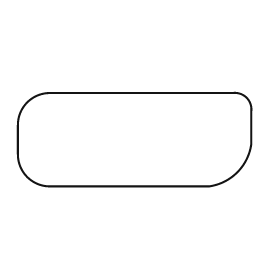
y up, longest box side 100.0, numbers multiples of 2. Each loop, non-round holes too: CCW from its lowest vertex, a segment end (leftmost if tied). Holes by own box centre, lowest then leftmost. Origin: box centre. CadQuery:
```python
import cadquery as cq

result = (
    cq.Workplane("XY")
    .moveTo(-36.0, -20.0)
    .lineTo(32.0, -20.0)
    .threePointArc((44.0, -14.0), (50.0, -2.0))
    .lineTo(50.0, 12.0)
    .threePointArc((48.0, 18.0), (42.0, 20.0))
    .lineTo(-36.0, 20.0)
    .threePointArc((-46.0, 16.0), (-50.0, 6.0))
    .lineTo(-50.0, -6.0)
    .threePointArc((-46.0, -16.0), (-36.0, -20.0))
    .close()
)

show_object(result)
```